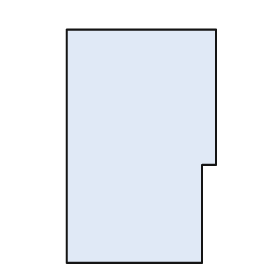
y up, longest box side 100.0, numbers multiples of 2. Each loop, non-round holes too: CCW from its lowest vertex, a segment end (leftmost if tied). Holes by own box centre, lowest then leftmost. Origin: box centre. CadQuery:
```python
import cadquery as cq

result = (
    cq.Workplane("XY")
    .moveTo(-32.0, -50.0)
    .lineTo(26.0, -50.0)
    .lineTo(26.0, -8.0)
    .lineTo(32.0, -8.0)
    .lineTo(32.0, 50.0)
    .lineTo(-32.0, 50.0)
    .close()
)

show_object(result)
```